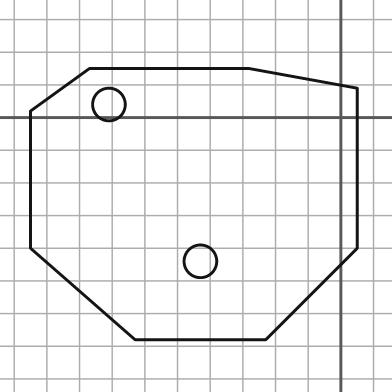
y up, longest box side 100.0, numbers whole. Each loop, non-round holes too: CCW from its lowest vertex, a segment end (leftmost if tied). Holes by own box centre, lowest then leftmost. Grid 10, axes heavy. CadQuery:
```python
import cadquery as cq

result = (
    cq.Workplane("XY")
    .moveTo(-63.0, -68.0)
    .lineTo(-23.0, -68.0)
    .lineTo(5.0, -40.0)
    .lineTo(5.0, 9.0)
    .lineTo(-28.0, 15.0)
    .lineTo(-77.0, 15.0)
    .lineTo(-95.0, 2.0)
    .lineTo(-95.0, -40.0)
    .close()
    .moveTo(-43.0, -44.0)
    .circle(5.0)
    .moveTo(-71.0, 4.0)
    .circle(5.0)
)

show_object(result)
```